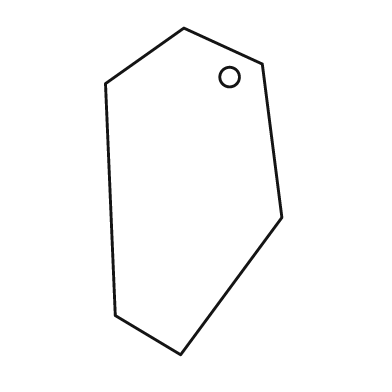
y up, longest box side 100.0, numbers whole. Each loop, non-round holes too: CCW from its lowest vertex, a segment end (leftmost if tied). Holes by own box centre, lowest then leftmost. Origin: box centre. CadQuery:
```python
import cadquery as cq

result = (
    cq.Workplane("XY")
    .moveTo(-4.0, -50.0)
    .lineTo(27.0, -8.0)
    .lineTo(21.0, 39.0)
    .lineTo(-3.0, 50.0)
    .lineTo(-27.0, 33.0)
    .lineTo(-24.0, -38.0)
    .close()
    .moveTo(11.0, 35.0)
    .circle(3.0)
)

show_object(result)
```